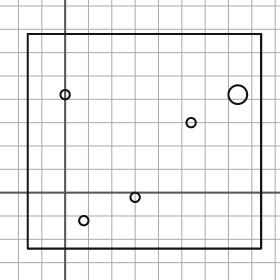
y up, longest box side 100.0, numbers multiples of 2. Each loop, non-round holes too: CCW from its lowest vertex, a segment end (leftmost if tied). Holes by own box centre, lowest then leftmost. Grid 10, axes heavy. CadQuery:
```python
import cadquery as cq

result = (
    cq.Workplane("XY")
    .moveTo(-16.0, -24.0)
    .lineTo(84.0, -24.0)
    .lineTo(84.0, 68.0)
    .lineTo(-16.0, 68.0)
    .close()
    .moveTo(8.0, -12.0)
    .circle(2.0)
    .moveTo(30.0, -2.0)
    .circle(2.0)
    .moveTo(54.0, 30.0)
    .circle(2.0)
    .moveTo(0.0, 42.0)
    .circle(2.0)
    .moveTo(74.0, 42.0)
    .circle(4.0)
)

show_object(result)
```